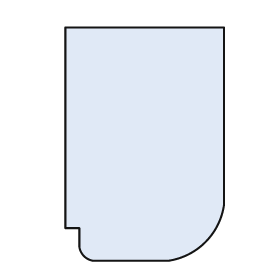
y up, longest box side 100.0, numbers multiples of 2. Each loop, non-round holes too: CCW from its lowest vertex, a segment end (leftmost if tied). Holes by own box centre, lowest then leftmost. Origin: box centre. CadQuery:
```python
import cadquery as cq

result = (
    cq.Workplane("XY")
    .moveTo(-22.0, -50.0)
    .lineTo(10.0, -50.0)
    .threePointArc((26.0, -42.0), (34.0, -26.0))
    .lineTo(34.0, 50.0)
    .lineTo(-34.0, 50.0)
    .lineTo(-34.0, -36.0)
    .lineTo(-28.0, -36.0)
    .lineTo(-28.0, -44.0)
    .threePointArc((-26.0, -48.0), (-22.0, -50.0))
    .close()
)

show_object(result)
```